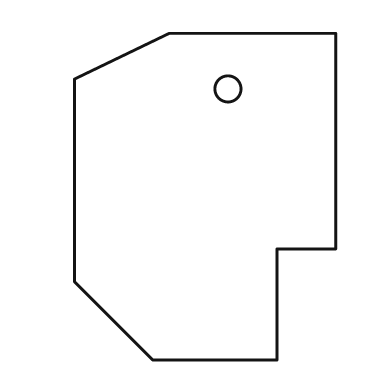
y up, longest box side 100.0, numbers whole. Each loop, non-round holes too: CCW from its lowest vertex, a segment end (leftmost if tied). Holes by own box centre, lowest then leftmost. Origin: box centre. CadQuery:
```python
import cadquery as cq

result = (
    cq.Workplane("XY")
    .moveTo(-16.0, -50.0)
    .lineTo(22.0, -50.0)
    .lineTo(22.0, -16.0)
    .lineTo(40.0, -16.0)
    .lineTo(40.0, 50.0)
    .lineTo(-11.0, 50.0)
    .lineTo(-40.0, 36.0)
    .lineTo(-40.0, -26.0)
    .close()
    .moveTo(7.0, 33.0)
    .circle(4.0)
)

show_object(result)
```